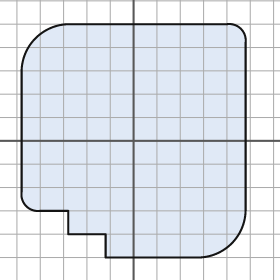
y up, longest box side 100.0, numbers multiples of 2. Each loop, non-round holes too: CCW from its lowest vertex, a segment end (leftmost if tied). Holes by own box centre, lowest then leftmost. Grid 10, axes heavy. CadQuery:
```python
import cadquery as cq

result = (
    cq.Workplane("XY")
    .moveTo(-12.0, -50.0)
    .lineTo(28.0, -50.0)
    .threePointArc((42.0, -44.0), (48.0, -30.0))
    .lineTo(48.0, 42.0)
    .threePointArc((46.0, 48.0), (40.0, 50.0))
    .lineTo(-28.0, 50.0)
    .threePointArc((-42.0, 44.0), (-48.0, 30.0))
    .lineTo(-48.0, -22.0)
    .threePointArc((-46.0, -28.0), (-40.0, -30.0))
    .lineTo(-28.0, -30.0)
    .lineTo(-28.0, -40.0)
    .lineTo(-12.0, -40.0)
    .close()
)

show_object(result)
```